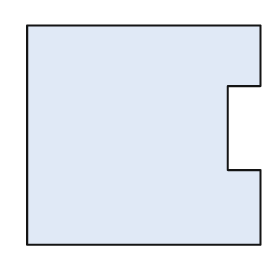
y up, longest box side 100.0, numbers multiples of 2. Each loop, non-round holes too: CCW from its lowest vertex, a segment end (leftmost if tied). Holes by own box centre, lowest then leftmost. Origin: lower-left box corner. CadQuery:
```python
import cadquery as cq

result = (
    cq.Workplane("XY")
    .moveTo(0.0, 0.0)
    .lineTo(100.0, 0.0)
    .lineTo(100.0, 32.0)
    .lineTo(86.0, 32.0)
    .lineTo(86.0, 68.0)
    .lineTo(100.0, 68.0)
    .lineTo(100.0, 94.0)
    .lineTo(0.0, 94.0)
    .close()
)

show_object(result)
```